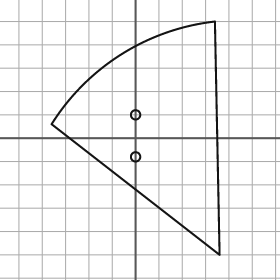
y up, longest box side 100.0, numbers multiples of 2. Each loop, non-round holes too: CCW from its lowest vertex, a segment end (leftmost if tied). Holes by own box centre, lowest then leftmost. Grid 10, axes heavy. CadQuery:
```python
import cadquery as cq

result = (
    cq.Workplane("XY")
    .moveTo(36.0, -50.0)
    .lineTo(34.0, 50.0)
    .threePointArc((-6.0, 36.0), (-36.0, 6.0))
    .close()
    .moveTo(0.0, -8.0)
    .circle(2.0)
    .moveTo(0.0, 10.0)
    .circle(2.0)
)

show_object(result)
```